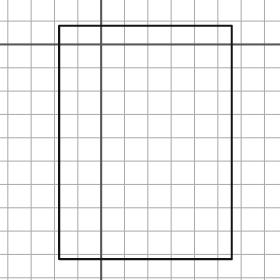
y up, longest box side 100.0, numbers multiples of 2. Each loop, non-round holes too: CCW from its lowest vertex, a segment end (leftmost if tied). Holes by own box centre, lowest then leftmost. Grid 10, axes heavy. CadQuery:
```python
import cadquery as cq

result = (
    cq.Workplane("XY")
    .moveTo(-18.0, -92.0)
    .lineTo(56.0, -92.0)
    .lineTo(56.0, 8.0)
    .lineTo(-18.0, 8.0)
    .close()
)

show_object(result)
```